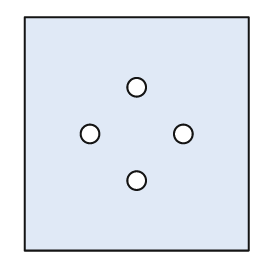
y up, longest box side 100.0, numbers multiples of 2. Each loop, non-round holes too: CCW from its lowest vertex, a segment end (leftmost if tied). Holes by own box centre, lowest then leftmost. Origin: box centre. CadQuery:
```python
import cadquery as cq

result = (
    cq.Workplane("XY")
    .moveTo(-48.0, -50.0)
    .lineTo(48.0, -50.0)
    .lineTo(48.0, 50.0)
    .lineTo(-48.0, 50.0)
    .close()
    .moveTo(0.0, -20.0)
    .circle(4.0)
    .moveTo(-20.0, 0.0)
    .circle(4.0)
    .moveTo(20.0, 0.0)
    .circle(4.0)
    .moveTo(0.0, 20.0)
    .circle(4.0)
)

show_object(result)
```